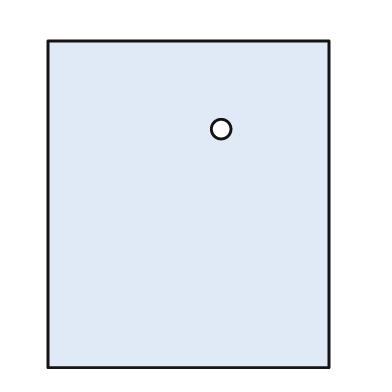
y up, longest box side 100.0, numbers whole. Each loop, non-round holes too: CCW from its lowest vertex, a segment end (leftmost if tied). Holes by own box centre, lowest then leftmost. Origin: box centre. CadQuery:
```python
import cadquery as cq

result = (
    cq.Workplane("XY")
    .moveTo(-43.0, -50.0)
    .lineTo(43.0, -50.0)
    .lineTo(43.0, 50.0)
    .lineTo(-43.0, 50.0)
    .close()
    .moveTo(10.0, 23.0)
    .circle(3.0)
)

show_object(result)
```